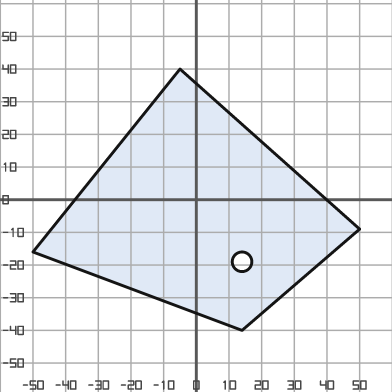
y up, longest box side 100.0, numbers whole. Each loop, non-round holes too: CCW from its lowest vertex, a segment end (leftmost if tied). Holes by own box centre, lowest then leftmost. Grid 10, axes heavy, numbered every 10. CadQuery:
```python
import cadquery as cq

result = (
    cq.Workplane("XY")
    .moveTo(14.0, -40.0)
    .lineTo(50.0, -9.0)
    .lineTo(-5.0, 40.0)
    .lineTo(-50.0, -16.0)
    .close()
    .moveTo(14.0, -19.0)
    .circle(3.0)
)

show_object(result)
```